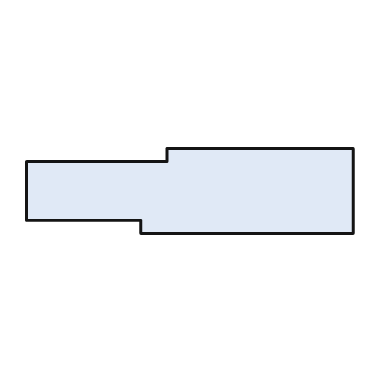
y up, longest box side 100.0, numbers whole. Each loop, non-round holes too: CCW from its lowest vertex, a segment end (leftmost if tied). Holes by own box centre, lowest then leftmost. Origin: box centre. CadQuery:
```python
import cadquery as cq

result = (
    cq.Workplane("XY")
    .moveTo(-15.0, -13.0)
    .lineTo(50.0, -13.0)
    .lineTo(50.0, 13.0)
    .lineTo(-7.0, 13.0)
    .lineTo(-7.0, 9.0)
    .lineTo(-50.0, 9.0)
    .lineTo(-50.0, -9.0)
    .lineTo(-15.0, -9.0)
    .close()
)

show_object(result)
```